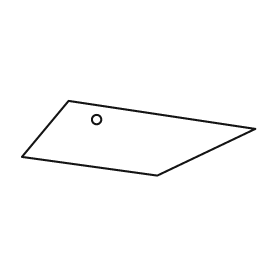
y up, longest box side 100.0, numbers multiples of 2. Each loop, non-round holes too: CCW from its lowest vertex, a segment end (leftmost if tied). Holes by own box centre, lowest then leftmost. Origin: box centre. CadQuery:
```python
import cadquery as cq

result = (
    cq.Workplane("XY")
    .moveTo(8.0, -16.0)
    .lineTo(50.0, 4.0)
    .lineTo(-30.0, 16.0)
    .lineTo(-50.0, -8.0)
    .close()
    .moveTo(-18.0, 8.0)
    .circle(2.0)
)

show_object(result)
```